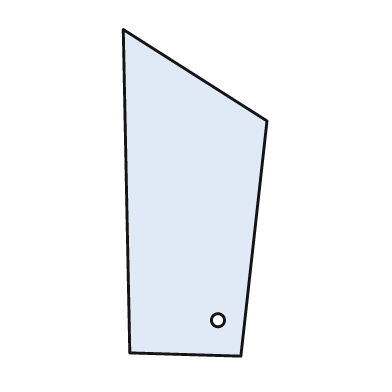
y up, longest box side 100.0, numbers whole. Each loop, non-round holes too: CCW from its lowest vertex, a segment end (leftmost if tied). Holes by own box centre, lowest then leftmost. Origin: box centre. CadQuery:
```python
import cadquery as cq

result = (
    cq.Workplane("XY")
    .moveTo(14.0, -50.0)
    .lineTo(22.0, 22.0)
    .lineTo(-22.0, 50.0)
    .lineTo(-20.0, -49.0)
    .close()
    .moveTo(7.0, -39.0)
    .circle(2.0)
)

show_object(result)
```